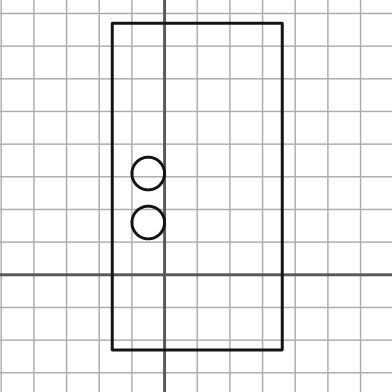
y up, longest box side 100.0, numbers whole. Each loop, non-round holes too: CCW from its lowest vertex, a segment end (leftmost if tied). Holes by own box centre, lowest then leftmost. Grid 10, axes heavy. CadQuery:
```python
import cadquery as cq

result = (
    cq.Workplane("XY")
    .moveTo(-16.0, -23.0)
    .lineTo(36.0, -23.0)
    .lineTo(36.0, 77.0)
    .lineTo(-16.0, 77.0)
    .close()
    .moveTo(-5.0, 16.0)
    .circle(5.0)
    .moveTo(-5.0, 31.0)
    .circle(5.0)
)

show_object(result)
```